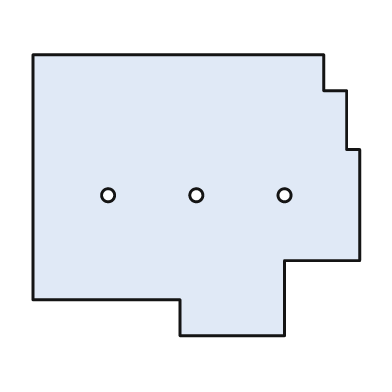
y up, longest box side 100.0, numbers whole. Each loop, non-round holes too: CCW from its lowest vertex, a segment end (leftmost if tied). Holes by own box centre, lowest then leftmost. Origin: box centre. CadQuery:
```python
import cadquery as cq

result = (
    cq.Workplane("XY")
    .moveTo(-5.0, -43.0)
    .lineTo(27.0, -43.0)
    .lineTo(27.0, -20.0)
    .lineTo(50.0, -20.0)
    .lineTo(50.0, 14.0)
    .lineTo(46.0, 14.0)
    .lineTo(46.0, 32.0)
    .lineTo(39.0, 32.0)
    .lineTo(39.0, 43.0)
    .lineTo(-50.0, 43.0)
    .lineTo(-50.0, -32.0)
    .lineTo(-5.0, -32.0)
    .close()
    .moveTo(-27.0, 0.0)
    .circle(2.0)
    .moveTo(0.0, 0.0)
    .circle(2.0)
    .moveTo(27.0, 0.0)
    .circle(2.0)
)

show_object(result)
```